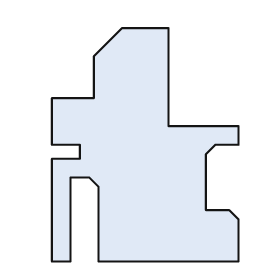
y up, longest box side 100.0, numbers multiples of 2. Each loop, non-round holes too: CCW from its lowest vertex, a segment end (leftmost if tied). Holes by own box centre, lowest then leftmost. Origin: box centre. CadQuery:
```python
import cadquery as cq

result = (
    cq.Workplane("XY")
    .moveTo(-40.0, -50.0)
    .lineTo(-32.0, -50.0)
    .lineTo(-32.0, -14.0)
    .lineTo(-24.0, -14.0)
    .lineTo(-20.0, -18.0)
    .lineTo(-20.0, -50.0)
    .lineTo(40.0, -50.0)
    .lineTo(40.0, -32.0)
    .lineTo(36.0, -28.0)
    .lineTo(26.0, -28.0)
    .lineTo(26.0, -4.0)
    .lineTo(30.0, 0.0)
    .lineTo(40.0, 0.0)
    .lineTo(40.0, 8.0)
    .lineTo(10.0, 8.0)
    .lineTo(10.0, 50.0)
    .lineTo(-10.0, 50.0)
    .lineTo(-22.0, 38.0)
    .lineTo(-22.0, 20.0)
    .lineTo(-40.0, 20.0)
    .lineTo(-40.0, 0.0)
    .lineTo(-28.0, 0.0)
    .lineTo(-28.0, -6.0)
    .lineTo(-40.0, -6.0)
    .close()
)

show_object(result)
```